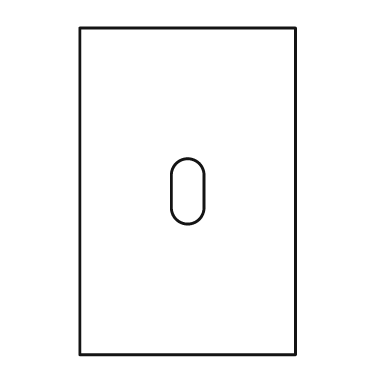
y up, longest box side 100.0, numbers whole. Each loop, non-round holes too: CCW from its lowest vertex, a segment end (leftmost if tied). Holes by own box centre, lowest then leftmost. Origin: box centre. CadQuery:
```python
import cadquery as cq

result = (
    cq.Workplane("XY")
    .moveTo(-33.0, -50.0)
    .lineTo(33.0, -50.0)
    .lineTo(33.0, 50.0)
    .lineTo(-33.0, 50.0)
    .close()
    .moveTo(-5.0, -5.0)
    .threePointArc((0.0, -10.0), (5.0, -5.0))
    .lineTo(5.0, 5.0)
    .threePointArc((0.0, 10.0), (-5.0, 5.0))
    .close()
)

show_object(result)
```